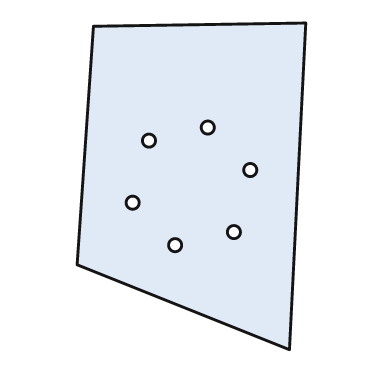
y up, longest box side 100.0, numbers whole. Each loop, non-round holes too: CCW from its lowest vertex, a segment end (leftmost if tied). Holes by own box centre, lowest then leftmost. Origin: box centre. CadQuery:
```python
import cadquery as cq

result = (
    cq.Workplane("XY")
    .moveTo(30.0, -50.0)
    .lineTo(35.0, 50.0)
    .lineTo(-30.0, 49.0)
    .lineTo(-35.0, -24.0)
    .close()
    .moveTo(-5.0, -18.0)
    .circle(2.0)
    .moveTo(13.0, -14.0)
    .circle(2.0)
    .moveTo(-18.0, -5.0)
    .circle(2.0)
    .moveTo(18.0, 5.0)
    .circle(2.0)
    .moveTo(-13.0, 14.0)
    .circle(2.0)
    .moveTo(5.0, 18.0)
    .circle(2.0)
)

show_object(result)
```